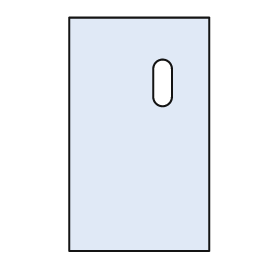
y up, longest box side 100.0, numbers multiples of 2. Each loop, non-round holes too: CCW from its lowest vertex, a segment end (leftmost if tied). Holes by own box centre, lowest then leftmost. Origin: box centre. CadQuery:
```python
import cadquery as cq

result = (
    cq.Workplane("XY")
    .moveTo(-30.0, -50.0)
    .lineTo(30.0, -50.0)
    .lineTo(30.0, 50.0)
    .lineTo(-30.0, 50.0)
    .close()
    .moveTo(6.0, 16.0)
    .threePointArc((10.0, 12.0), (14.0, 16.0))
    .lineTo(14.0, 28.0)
    .threePointArc((10.0, 32.0), (6.0, 28.0))
    .close()
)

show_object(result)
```